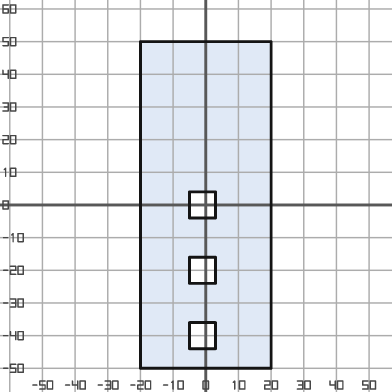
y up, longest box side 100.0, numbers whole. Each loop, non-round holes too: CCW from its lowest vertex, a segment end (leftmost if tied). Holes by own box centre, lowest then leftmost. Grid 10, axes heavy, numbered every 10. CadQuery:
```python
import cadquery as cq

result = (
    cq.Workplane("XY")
    .moveTo(-20.0, -50.0)
    .lineTo(20.0, -50.0)
    .lineTo(20.0, 50.0)
    .lineTo(-20.0, 50.0)
    .close()
    .moveTo(-5.0, -44.0)
    .lineTo(3.0, -44.0)
    .lineTo(3.0, -36.0)
    .lineTo(-5.0, -36.0)
    .close()
    .moveTo(-5.0, -24.0)
    .lineTo(3.0, -24.0)
    .lineTo(3.0, -16.0)
    .lineTo(-5.0, -16.0)
    .close()
    .moveTo(-5.0, -4.0)
    .lineTo(3.0, -4.0)
    .lineTo(3.0, 4.0)
    .lineTo(-5.0, 4.0)
    .close()
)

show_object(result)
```